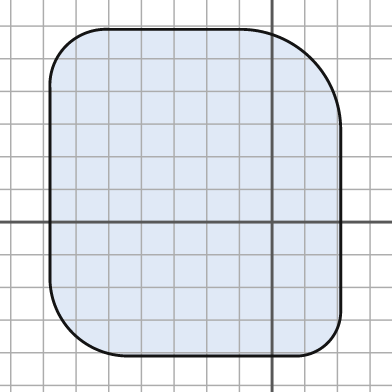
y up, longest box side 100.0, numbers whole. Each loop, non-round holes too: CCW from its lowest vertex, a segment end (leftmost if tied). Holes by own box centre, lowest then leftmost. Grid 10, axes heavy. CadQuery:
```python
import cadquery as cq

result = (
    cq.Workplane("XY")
    .moveTo(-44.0, -41.0)
    .lineTo(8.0, -41.0)
    .threePointArc((17.0, -37.0), (21.0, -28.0))
    .lineTo(21.0, 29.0)
    .threePointArc((12.0, 50.0), (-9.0, 59.0))
    .lineTo(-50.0, 59.0)
    .threePointArc((-63.0, 54.0), (-68.0, 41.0))
    .lineTo(-68.0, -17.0)
    .threePointArc((-61.0, -34.0), (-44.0, -41.0))
    .close()
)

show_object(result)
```